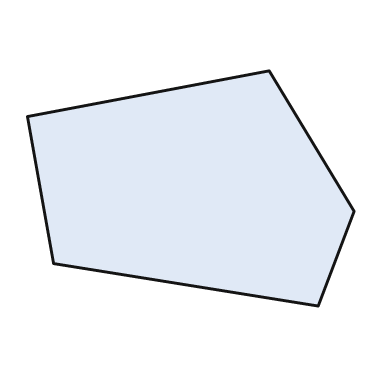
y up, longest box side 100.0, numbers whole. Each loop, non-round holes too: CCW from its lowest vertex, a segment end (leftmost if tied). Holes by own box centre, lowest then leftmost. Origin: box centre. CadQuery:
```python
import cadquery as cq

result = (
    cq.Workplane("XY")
    .moveTo(39.0, -36.0)
    .lineTo(50.0, -7.0)
    .lineTo(24.0, 36.0)
    .lineTo(-50.0, 22.0)
    .lineTo(-42.0, -23.0)
    .close()
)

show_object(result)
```